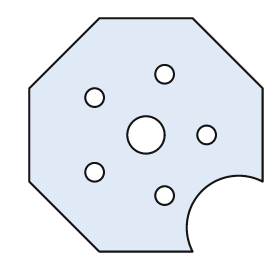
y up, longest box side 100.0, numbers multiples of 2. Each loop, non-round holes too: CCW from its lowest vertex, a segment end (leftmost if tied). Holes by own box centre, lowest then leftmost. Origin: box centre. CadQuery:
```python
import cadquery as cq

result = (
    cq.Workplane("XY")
    .moveTo(-20.0, -50.0)
    .lineTo(20.0, -50.0)
    .threePointArc((24.0, -24.0), (50.0, -20.0))
    .lineTo(50.0, 20.0)
    .lineTo(20.0, 50.0)
    .lineTo(-20.0, 50.0)
    .lineTo(-50.0, 20.0)
    .lineTo(-50.0, -20.0)
    .close()
    .moveTo(8.0, -26.0)
    .circle(4.0)
    .moveTo(-22.0, -16.0)
    .circle(4.0)
    .moveTo(0.0, 0.0)
    .circle(8.0)
    .moveTo(26.0, 0.0)
    .circle(4.0)
    .moveTo(-22.0, 16.0)
    .circle(4.0)
    .moveTo(8.0, 26.0)
    .circle(4.0)
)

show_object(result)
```